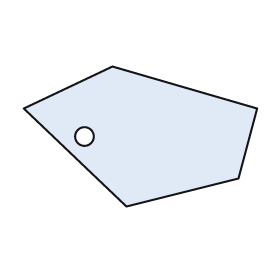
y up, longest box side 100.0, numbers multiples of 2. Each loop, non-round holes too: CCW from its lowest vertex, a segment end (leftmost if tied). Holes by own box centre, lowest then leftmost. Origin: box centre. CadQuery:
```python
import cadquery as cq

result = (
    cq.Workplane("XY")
    .moveTo(-6.0, -30.0)
    .lineTo(42.0, -18.0)
    .lineTo(50.0, 12.0)
    .lineTo(-12.0, 30.0)
    .lineTo(-50.0, 12.0)
    .close()
    .moveTo(-24.0, 0.0)
    .circle(4.0)
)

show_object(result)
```